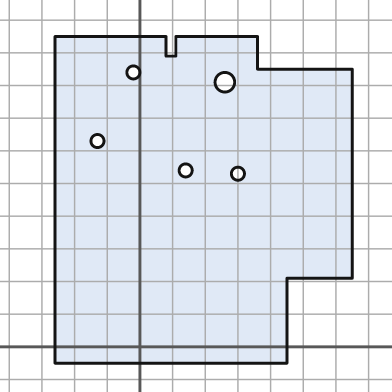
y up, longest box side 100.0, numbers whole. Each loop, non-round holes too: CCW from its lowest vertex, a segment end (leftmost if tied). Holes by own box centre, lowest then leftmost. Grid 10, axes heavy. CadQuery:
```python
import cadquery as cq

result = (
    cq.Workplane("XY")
    .moveTo(-26.0, -5.0)
    .lineTo(45.0, -5.0)
    .lineTo(45.0, 21.0)
    .lineTo(65.0, 21.0)
    .lineTo(65.0, 85.0)
    .lineTo(36.0, 85.0)
    .lineTo(36.0, 95.0)
    .lineTo(11.0, 95.0)
    .lineTo(11.0, 89.0)
    .lineTo(8.0, 89.0)
    .lineTo(8.0, 95.0)
    .lineTo(-26.0, 95.0)
    .close()
    .moveTo(30.0, 53.0)
    .circle(2.0)
    .moveTo(14.0, 54.0)
    .circle(2.0)
    .moveTo(-13.0, 63.0)
    .circle(2.0)
    .moveTo(26.0, 81.0)
    .circle(3.0)
    .moveTo(-2.0, 84.0)
    .circle(2.0)
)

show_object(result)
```